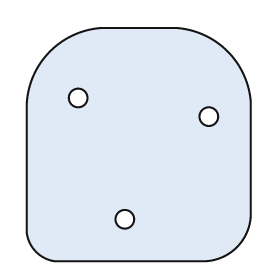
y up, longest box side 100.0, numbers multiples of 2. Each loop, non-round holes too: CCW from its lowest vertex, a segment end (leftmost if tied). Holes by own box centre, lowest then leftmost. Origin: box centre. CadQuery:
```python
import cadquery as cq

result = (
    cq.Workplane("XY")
    .moveTo(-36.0, -50.0)
    .lineTo(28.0, -50.0)
    .threePointArc((42.0, -44.0), (48.0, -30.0))
    .lineTo(48.0, 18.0)
    .threePointArc((38.0, 40.0), (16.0, 50.0))
    .lineTo(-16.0, 50.0)
    .threePointArc((-38.0, 40.0), (-48.0, 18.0))
    .lineTo(-48.0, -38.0)
    .threePointArc((-44.0, -46.0), (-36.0, -50.0))
    .close()
    .moveTo(-6.0, -32.0)
    .circle(4.0)
    .moveTo(30.0, 12.0)
    .circle(4.0)
    .moveTo(-26.0, 20.0)
    .circle(4.0)
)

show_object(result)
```